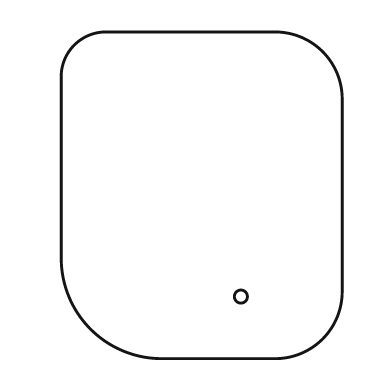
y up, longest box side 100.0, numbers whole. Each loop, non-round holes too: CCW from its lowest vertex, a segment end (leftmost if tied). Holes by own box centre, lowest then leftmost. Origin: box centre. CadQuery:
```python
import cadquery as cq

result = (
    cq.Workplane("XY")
    .moveTo(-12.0, -50.0)
    .lineTo(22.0, -50.0)
    .threePointArc((37.0, -44.0), (43.0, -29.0))
    .lineTo(43.0, 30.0)
    .threePointArc((37.0, 44.0), (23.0, 50.0))
    .lineTo(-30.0, 50.0)
    .threePointArc((-39.0, 46.0), (-43.0, 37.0))
    .lineTo(-43.0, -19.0)
    .threePointArc((-34.0, -41.0), (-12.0, -50.0))
    .close()
    .moveTo(12.0, -31.0)
    .circle(2.0)
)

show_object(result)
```